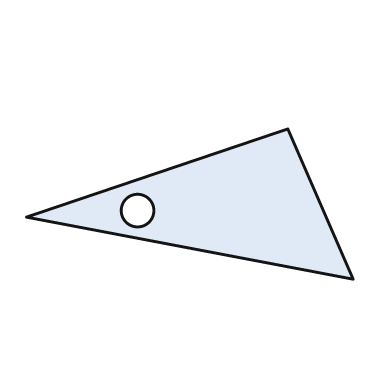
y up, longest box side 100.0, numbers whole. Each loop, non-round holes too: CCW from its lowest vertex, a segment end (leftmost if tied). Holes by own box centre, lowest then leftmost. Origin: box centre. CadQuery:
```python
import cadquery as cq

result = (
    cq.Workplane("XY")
    .moveTo(50.0, -23.0)
    .lineTo(30.0, 23.0)
    .lineTo(-50.0, -4.0)
    .close()
    .moveTo(-16.0, -2.0)
    .circle(5.0)
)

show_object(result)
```